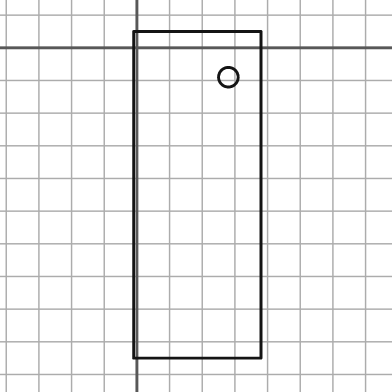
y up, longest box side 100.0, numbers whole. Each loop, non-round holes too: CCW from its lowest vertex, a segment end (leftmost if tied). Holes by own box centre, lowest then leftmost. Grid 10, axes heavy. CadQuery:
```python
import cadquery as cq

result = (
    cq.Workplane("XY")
    .moveTo(-1.0, -95.0)
    .lineTo(38.0, -95.0)
    .lineTo(38.0, 5.0)
    .lineTo(-1.0, 5.0)
    .close()
    .moveTo(28.0, -9.0)
    .circle(3.0)
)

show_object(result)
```